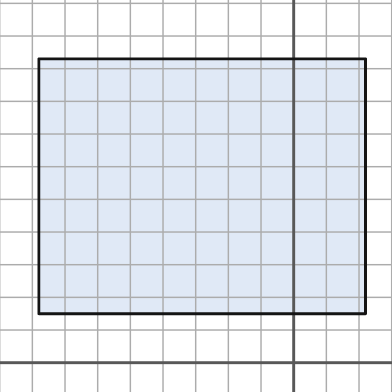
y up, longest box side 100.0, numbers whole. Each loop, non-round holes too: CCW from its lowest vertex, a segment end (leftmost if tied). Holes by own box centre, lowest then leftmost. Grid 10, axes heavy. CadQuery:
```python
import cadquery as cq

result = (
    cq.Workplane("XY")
    .moveTo(-78.0, 15.0)
    .lineTo(22.0, 15.0)
    .lineTo(22.0, 93.0)
    .lineTo(-78.0, 93.0)
    .close()
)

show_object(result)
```